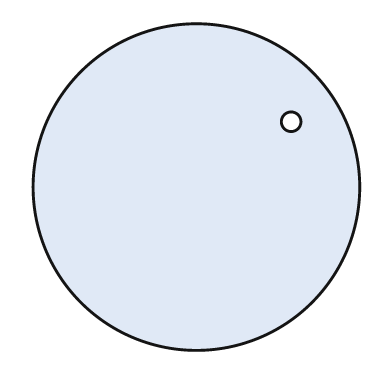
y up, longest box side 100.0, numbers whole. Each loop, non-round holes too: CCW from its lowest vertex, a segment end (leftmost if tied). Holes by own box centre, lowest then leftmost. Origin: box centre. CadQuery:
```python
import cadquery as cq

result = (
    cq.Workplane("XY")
    .moveTo(0.0, 0.0)
    .circle(50.0)
    .moveTo(29.0, 20.0)
    .circle(3.0)
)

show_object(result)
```